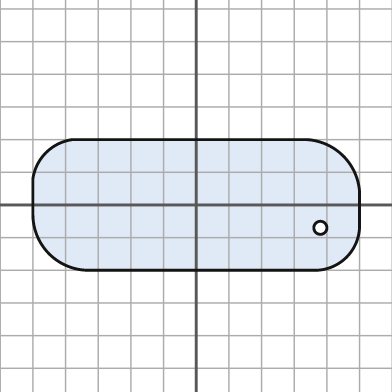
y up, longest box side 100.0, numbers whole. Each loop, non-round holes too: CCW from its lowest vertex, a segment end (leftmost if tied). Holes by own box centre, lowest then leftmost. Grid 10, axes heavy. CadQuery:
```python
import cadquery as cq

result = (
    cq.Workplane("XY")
    .moveTo(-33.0, -20.0)
    .lineTo(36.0, -20.0)
    .threePointArc((46.0, -16.0), (50.0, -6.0))
    .lineTo(50.0, 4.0)
    .threePointArc((45.0, 15.0), (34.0, 20.0))
    .lineTo(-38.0, 20.0)
    .threePointArc((-46.0, 16.0), (-50.0, 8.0))
    .lineTo(-50.0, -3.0)
    .threePointArc((-45.0, -15.0), (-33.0, -20.0))
    .close()
    .moveTo(38.0, -7.0)
    .circle(2.0)
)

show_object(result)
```